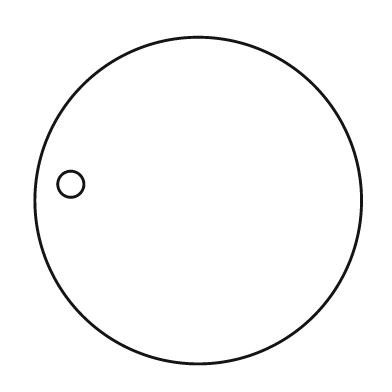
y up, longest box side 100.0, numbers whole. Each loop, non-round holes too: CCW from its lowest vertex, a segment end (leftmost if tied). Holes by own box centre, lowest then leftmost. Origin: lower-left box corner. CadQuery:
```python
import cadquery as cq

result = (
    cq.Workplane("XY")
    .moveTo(50.0, 50.0)
    .circle(50.0)
    .moveTo(11.0, 55.0)
    .circle(4.0)
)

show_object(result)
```